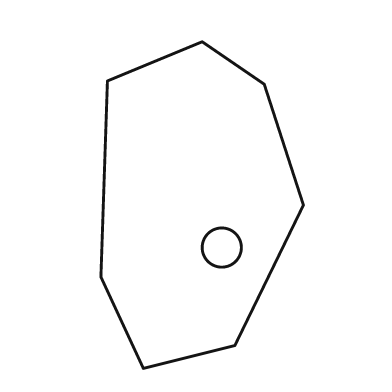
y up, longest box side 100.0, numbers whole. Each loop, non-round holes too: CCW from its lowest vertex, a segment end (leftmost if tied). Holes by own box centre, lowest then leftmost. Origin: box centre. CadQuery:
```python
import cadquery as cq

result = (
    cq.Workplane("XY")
    .moveTo(-18.0, -50.0)
    .lineTo(10.0, -43.0)
    .lineTo(31.0, 0.0)
    .lineTo(19.0, 37.0)
    .lineTo(0.0, 50.0)
    .lineTo(-29.0, 38.0)
    .lineTo(-31.0, -22.0)
    .close()
    .moveTo(6.0, -13.0)
    .circle(6.0)
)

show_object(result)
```